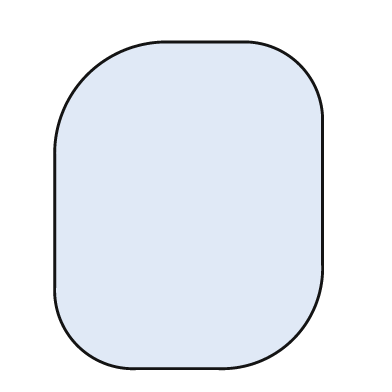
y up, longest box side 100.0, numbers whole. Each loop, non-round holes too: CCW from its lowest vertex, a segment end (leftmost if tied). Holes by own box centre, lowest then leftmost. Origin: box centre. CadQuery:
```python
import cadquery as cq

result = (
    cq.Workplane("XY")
    .moveTo(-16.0, -50.0)
    .lineTo(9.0, -50.0)
    .threePointArc((32.0, -41.0), (41.0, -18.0))
    .lineTo(41.0, 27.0)
    .threePointArc((34.0, 43.0), (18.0, 50.0))
    .lineTo(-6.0, 50.0)
    .threePointArc((-31.0, 40.0), (-41.0, 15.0))
    .lineTo(-41.0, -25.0)
    .threePointArc((-34.0, -43.0), (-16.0, -50.0))
    .close()
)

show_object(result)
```